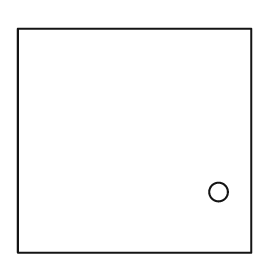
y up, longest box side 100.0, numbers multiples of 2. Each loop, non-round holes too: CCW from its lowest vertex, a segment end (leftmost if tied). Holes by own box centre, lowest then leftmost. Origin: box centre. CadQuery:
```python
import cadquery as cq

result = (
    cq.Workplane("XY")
    .moveTo(-50.0, -48.0)
    .lineTo(50.0, -48.0)
    .lineTo(50.0, 48.0)
    .lineTo(-50.0, 48.0)
    .close()
    .moveTo(36.0, -22.0)
    .circle(4.0)
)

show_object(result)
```